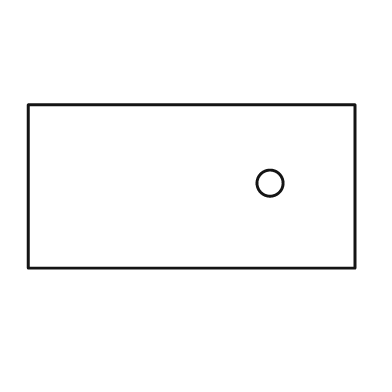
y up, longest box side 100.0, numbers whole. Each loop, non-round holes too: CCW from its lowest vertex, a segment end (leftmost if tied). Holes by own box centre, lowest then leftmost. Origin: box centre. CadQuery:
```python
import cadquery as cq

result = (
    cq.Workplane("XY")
    .moveTo(-50.0, -25.0)
    .lineTo(50.0, -25.0)
    .lineTo(50.0, 25.0)
    .lineTo(-50.0, 25.0)
    .close()
    .moveTo(24.0, 1.0)
    .circle(4.0)
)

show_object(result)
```